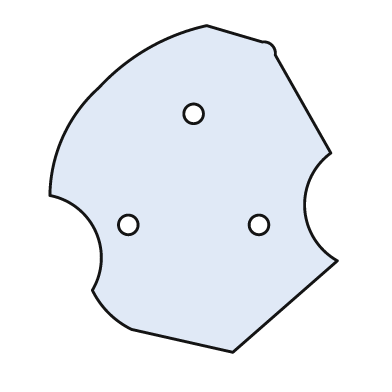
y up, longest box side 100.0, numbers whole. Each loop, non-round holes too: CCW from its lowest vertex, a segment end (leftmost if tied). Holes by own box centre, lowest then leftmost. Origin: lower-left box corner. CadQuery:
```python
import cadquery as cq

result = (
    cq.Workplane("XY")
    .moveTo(56.0, 0.0)
    .lineTo(88.0, 28.0)
    .threePointArc((78.0, 44.0), (86.0, 61.0))
    .lineTo(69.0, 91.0)
    .threePointArc((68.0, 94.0), (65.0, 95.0))
    .lineTo(48.0, 100.0)
    .threePointArc((30.0, 93.0), (15.0, 81.0))
    .threePointArc((4.0, 66.0), (0.0, 48.0))
    .threePointArc((14.0, 37.0), (13.0, 19.0))
    .threePointArc((18.0, 12.0), (25.0, 7.0))
    .close()
    .moveTo(24.0, 39.0)
    .circle(3.0)
    .moveTo(64.0, 39.0)
    .circle(3.0)
    .moveTo(44.0, 73.0)
    .circle(3.0)
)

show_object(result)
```